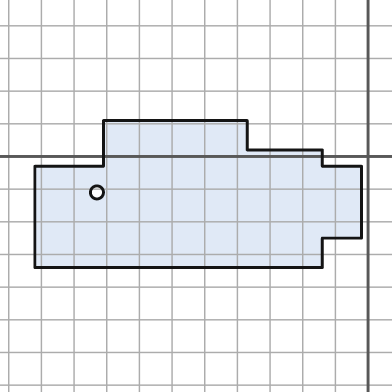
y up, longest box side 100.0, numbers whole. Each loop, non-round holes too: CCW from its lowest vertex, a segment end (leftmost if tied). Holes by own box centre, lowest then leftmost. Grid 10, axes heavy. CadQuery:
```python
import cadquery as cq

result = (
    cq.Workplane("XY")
    .moveTo(-102.0, -34.0)
    .lineTo(-14.0, -34.0)
    .lineTo(-14.0, -25.0)
    .lineTo(-2.0, -25.0)
    .lineTo(-2.0, -3.0)
    .lineTo(-14.0, -3.0)
    .lineTo(-14.0, 2.0)
    .lineTo(-37.0, 2.0)
    .lineTo(-37.0, 11.0)
    .lineTo(-81.0, 11.0)
    .lineTo(-81.0, -3.0)
    .lineTo(-102.0, -3.0)
    .close()
    .moveTo(-83.0, -11.0)
    .circle(2.0)
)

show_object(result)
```